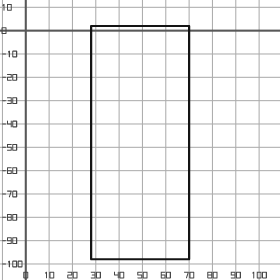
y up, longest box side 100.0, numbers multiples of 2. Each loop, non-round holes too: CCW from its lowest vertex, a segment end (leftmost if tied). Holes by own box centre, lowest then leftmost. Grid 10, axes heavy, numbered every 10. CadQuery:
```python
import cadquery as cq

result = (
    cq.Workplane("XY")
    .moveTo(28.0, -98.0)
    .lineTo(70.0, -98.0)
    .lineTo(70.0, 2.0)
    .lineTo(28.0, 2.0)
    .close()
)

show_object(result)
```